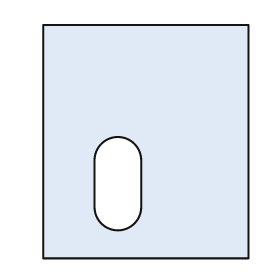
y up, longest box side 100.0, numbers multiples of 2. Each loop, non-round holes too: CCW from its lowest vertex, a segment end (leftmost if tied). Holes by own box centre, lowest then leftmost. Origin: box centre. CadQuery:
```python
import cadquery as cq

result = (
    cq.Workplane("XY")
    .moveTo(-44.0, -50.0)
    .lineTo(44.0, -50.0)
    .lineTo(44.0, 50.0)
    .lineTo(-44.0, 50.0)
    .close()
    .moveTo(-22.0, -28.0)
    .threePointArc((-12.0, -38.0), (-2.0, -28.0))
    .lineTo(-2.0, -8.0)
    .threePointArc((-12.0, 2.0), (-22.0, -8.0))
    .close()
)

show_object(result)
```